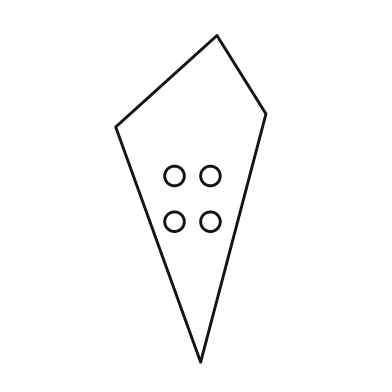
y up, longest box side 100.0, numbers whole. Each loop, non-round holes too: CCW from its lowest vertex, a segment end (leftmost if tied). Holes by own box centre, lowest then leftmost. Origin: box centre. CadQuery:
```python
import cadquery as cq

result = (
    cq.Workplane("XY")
    .moveTo(3.0, -50.0)
    .lineTo(23.0, 26.0)
    .lineTo(8.0, 50.0)
    .lineTo(-23.0, 22.0)
    .close()
    .moveTo(-5.0, -7.0)
    .circle(3.0)
    .moveTo(6.0, -7.0)
    .circle(3.0)
    .moveTo(-5.0, 7.0)
    .circle(3.0)
    .moveTo(6.0, 7.0)
    .circle(3.0)
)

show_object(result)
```